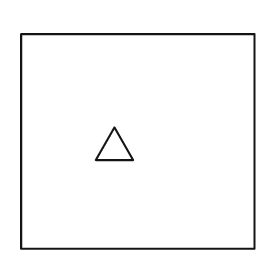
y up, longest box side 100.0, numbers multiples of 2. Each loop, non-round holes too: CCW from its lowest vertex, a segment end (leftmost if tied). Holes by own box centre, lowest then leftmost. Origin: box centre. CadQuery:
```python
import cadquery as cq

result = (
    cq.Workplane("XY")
    .moveTo(-50.0, -46.0)
    .lineTo(50.0, -46.0)
    .lineTo(50.0, 46.0)
    .lineTo(-50.0, 46.0)
    .close()
    .moveTo(-18.0, -8.0)
    .lineTo(-2.0, -8.0)
    .lineTo(-10.0, 6.0)
    .close()
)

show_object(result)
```